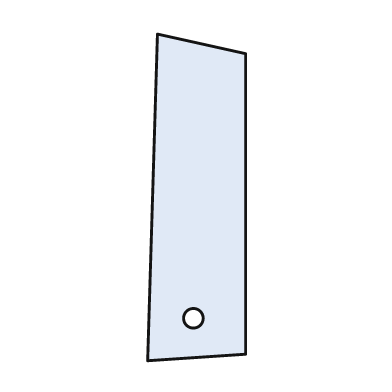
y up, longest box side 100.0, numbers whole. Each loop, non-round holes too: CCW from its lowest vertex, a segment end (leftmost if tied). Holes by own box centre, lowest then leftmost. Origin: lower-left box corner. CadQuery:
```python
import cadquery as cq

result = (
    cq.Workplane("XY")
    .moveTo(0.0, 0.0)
    .lineTo(30.0, 2.0)
    .lineTo(30.0, 94.0)
    .lineTo(3.0, 100.0)
    .close()
    .moveTo(14.0, 13.0)
    .circle(3.0)
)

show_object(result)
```